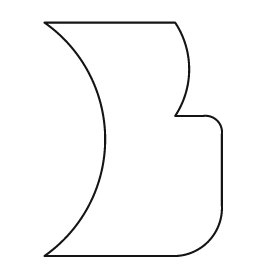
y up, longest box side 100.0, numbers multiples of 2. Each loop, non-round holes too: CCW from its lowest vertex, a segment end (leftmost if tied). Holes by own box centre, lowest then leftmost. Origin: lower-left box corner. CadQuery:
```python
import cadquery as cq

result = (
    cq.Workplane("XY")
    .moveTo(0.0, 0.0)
    .lineTo(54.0, 0.0)
    .threePointArc((70.0, 6.0), (76.0, 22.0))
    .lineTo(76.0, 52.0)
    .threePointArc((74.0, 58.0), (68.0, 60.0))
    .lineTo(56.0, 60.0)
    .threePointArc((62.0, 80.0), (56.0, 100.0))
    .lineTo(0.0, 100.0)
    .threePointArc((26.0, 50.0), (0.0, 0.0))
    .close()
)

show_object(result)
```